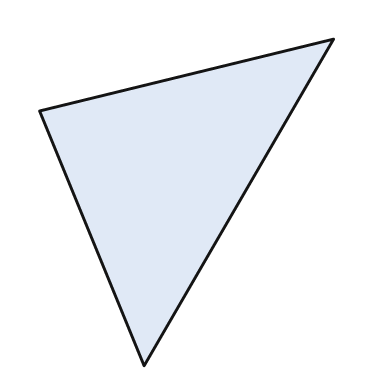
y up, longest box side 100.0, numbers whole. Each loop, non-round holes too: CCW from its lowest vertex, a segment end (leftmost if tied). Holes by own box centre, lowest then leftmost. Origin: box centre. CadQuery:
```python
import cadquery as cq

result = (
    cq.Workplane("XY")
    .moveTo(-13.0, -50.0)
    .lineTo(45.0, 50.0)
    .lineTo(-45.0, 28.0)
    .close()
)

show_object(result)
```